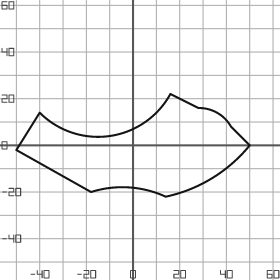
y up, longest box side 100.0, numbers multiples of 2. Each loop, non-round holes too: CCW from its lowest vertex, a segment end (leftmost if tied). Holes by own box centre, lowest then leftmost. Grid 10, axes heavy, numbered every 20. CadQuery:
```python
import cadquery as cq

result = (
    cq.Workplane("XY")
    .moveTo(14.0, -22.0)
    .threePointArc((34.0, -14.0), (50.0, 0.0))
    .lineTo(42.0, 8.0)
    .threePointArc((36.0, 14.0), (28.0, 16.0))
    .lineTo(16.0, 22.0)
    .threePointArc((-10.0, 4.0), (-40.0, 14.0))
    .lineTo(-50.0, -2.0)
    .lineTo(-18.0, -20.0)
    .threePointArc((-2.0, -18.0), (14.0, -22.0))
    .close()
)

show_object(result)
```